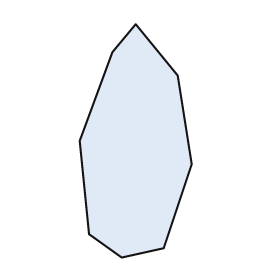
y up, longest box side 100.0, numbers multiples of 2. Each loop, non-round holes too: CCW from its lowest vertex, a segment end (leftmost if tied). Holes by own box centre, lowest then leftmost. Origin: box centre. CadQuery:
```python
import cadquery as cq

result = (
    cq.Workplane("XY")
    .moveTo(-6.0, -50.0)
    .lineTo(12.0, -46.0)
    .lineTo(24.0, -10.0)
    .lineTo(18.0, 28.0)
    .lineTo(0.0, 50.0)
    .lineTo(-10.0, 38.0)
    .lineTo(-24.0, 0.0)
    .lineTo(-20.0, -40.0)
    .close()
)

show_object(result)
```